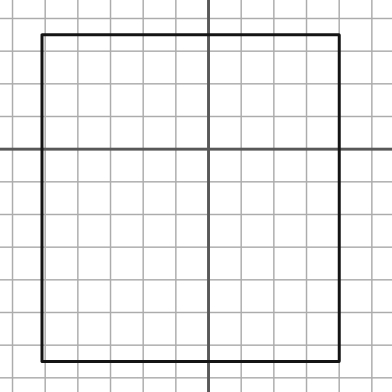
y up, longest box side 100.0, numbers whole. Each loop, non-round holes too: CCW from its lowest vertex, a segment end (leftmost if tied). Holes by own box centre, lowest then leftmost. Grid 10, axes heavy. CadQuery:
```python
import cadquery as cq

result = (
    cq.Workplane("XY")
    .moveTo(-51.0, -65.0)
    .lineTo(40.0, -65.0)
    .lineTo(40.0, 35.0)
    .lineTo(-51.0, 35.0)
    .close()
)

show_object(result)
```